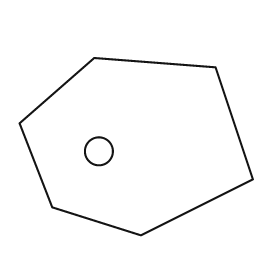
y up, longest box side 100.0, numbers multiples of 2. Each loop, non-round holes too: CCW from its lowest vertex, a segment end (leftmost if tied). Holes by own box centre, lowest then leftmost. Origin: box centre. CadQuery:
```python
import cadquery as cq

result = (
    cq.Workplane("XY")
    .moveTo(2.0, -38.0)
    .lineTo(50.0, -14.0)
    .lineTo(34.0, 34.0)
    .lineTo(-18.0, 38.0)
    .lineTo(-50.0, 10.0)
    .lineTo(-36.0, -26.0)
    .close()
    .moveTo(-16.0, -2.0)
    .circle(6.0)
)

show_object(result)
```